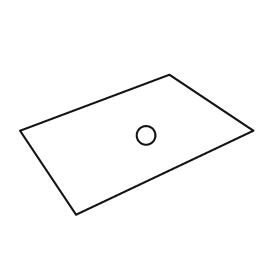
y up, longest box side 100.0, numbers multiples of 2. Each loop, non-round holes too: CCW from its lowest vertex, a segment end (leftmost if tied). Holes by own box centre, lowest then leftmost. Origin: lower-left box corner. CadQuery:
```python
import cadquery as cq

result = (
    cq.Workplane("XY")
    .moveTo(24.0, 0.0)
    .lineTo(100.0, 36.0)
    .lineTo(64.0, 60.0)
    .lineTo(0.0, 36.0)
    .close()
    .moveTo(54.0, 34.0)
    .circle(4.0)
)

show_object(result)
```